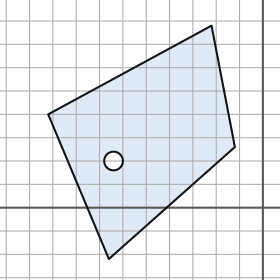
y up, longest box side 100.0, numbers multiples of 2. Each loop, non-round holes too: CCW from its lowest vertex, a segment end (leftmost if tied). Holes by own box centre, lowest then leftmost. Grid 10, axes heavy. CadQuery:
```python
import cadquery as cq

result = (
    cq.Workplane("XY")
    .moveTo(-66.0, -22.0)
    .lineTo(-12.0, 26.0)
    .lineTo(-22.0, 78.0)
    .lineTo(-92.0, 40.0)
    .close()
    .moveTo(-64.0, 20.0)
    .circle(4.0)
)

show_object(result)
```